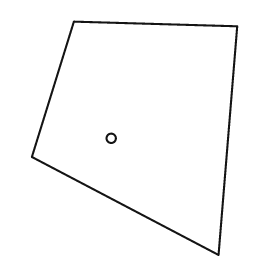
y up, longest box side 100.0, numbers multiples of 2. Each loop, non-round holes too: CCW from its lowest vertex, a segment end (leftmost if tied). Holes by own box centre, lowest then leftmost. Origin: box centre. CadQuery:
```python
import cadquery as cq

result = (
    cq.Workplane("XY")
    .moveTo(36.0, -50.0)
    .lineTo(44.0, 48.0)
    .lineTo(-26.0, 50.0)
    .lineTo(-44.0, -8.0)
    .close()
    .moveTo(-10.0, 0.0)
    .circle(2.0)
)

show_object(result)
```